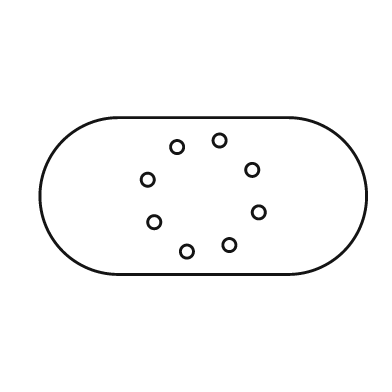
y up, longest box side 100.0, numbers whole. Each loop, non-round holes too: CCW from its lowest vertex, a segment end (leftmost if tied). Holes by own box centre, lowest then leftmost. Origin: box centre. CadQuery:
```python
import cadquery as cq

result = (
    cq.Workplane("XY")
    .moveTo(-26.0, -24.0)
    .lineTo(26.0, -24.0)
    .threePointArc((50.0, 0.0), (26.0, 24.0))
    .lineTo(-26.0, 24.0)
    .threePointArc((-50.0, 0.0), (-26.0, -24.0))
    .close()
    .moveTo(-5.0, -17.0)
    .circle(2.0)
    .moveTo(8.0, -15.0)
    .circle(2.0)
    .moveTo(-15.0, -8.0)
    .circle(2.0)
    .moveTo(17.0, -5.0)
    .circle(2.0)
    .moveTo(-17.0, 5.0)
    .circle(2.0)
    .moveTo(15.0, 8.0)
    .circle(2.0)
    .moveTo(-8.0, 15.0)
    .circle(2.0)
    .moveTo(5.0, 17.0)
    .circle(2.0)
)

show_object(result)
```